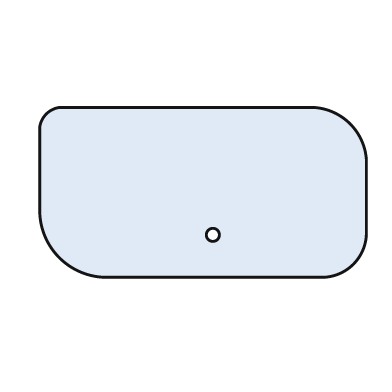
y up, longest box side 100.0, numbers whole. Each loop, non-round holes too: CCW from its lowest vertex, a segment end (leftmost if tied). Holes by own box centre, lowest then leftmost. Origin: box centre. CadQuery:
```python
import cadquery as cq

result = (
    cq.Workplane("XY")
    .moveTo(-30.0, -26.0)
    .lineTo(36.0, -26.0)
    .threePointArc((46.0, -22.0), (50.0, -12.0))
    .lineTo(50.0, 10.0)
    .threePointArc((45.0, 21.0), (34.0, 26.0))
    .lineTo(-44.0, 26.0)
    .threePointArc((-48.0, 24.0), (-50.0, 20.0))
    .lineTo(-50.0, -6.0)
    .threePointArc((-44.0, -20.0), (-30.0, -26.0))
    .close()
    .moveTo(3.0, -13.0)
    .circle(2.0)
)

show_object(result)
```